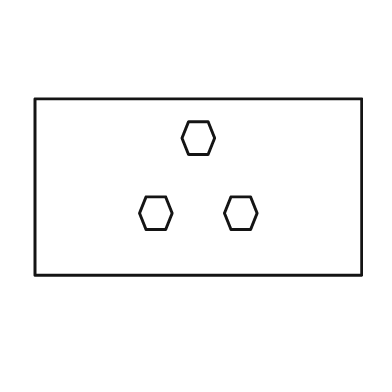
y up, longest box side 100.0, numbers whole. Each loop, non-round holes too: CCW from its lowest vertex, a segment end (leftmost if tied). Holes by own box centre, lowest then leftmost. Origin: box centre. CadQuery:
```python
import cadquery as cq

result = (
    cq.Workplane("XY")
    .moveTo(-50.0, -27.0)
    .lineTo(50.0, -27.0)
    .lineTo(50.0, 27.0)
    .lineTo(-50.0, 27.0)
    .close()
    .moveTo(-16.0, -13.0)
    .lineTo(-10.0, -13.0)
    .lineTo(-8.0, -8.0)
    .lineTo(-10.0, -3.0)
    .lineTo(-16.0, -3.0)
    .lineTo(-18.0, -8.0)
    .close()
    .moveTo(10.0, -13.0)
    .lineTo(16.0, -13.0)
    .lineTo(18.0, -8.0)
    .lineTo(16.0, -3.0)
    .lineTo(10.0, -3.0)
    .lineTo(8.0, -8.0)
    .close()
    .moveTo(-3.0, 10.0)
    .lineTo(3.0, 10.0)
    .lineTo(5.0, 15.0)
    .lineTo(3.0, 20.0)
    .lineTo(-3.0, 20.0)
    .lineTo(-5.0, 15.0)
    .close()
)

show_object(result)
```